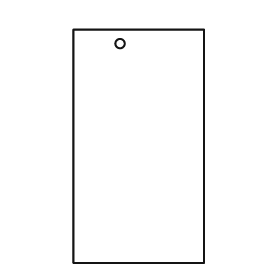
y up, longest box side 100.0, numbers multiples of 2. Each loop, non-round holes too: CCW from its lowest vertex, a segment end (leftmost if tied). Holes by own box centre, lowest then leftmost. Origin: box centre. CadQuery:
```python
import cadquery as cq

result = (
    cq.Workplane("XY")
    .moveTo(-28.0, -50.0)
    .lineTo(28.0, -50.0)
    .lineTo(28.0, 50.0)
    .lineTo(-28.0, 50.0)
    .close()
    .moveTo(-8.0, 44.0)
    .circle(2.0)
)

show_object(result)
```